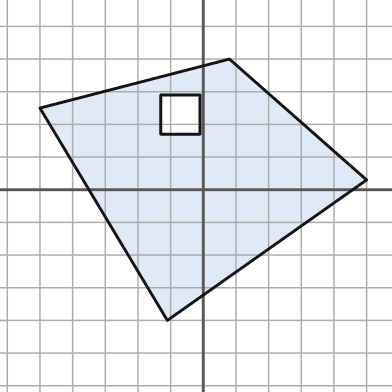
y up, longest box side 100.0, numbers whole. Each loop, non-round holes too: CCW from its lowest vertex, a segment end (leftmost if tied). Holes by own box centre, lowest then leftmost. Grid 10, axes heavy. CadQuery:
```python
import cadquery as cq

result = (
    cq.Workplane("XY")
    .moveTo(-11.0, -40.0)
    .lineTo(50.0, 3.0)
    .lineTo(8.0, 40.0)
    .lineTo(-50.0, 25.0)
    .close()
    .moveTo(-13.0, 17.0)
    .lineTo(-1.0, 17.0)
    .lineTo(-1.0, 29.0)
    .lineTo(-13.0, 29.0)
    .close()
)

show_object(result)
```